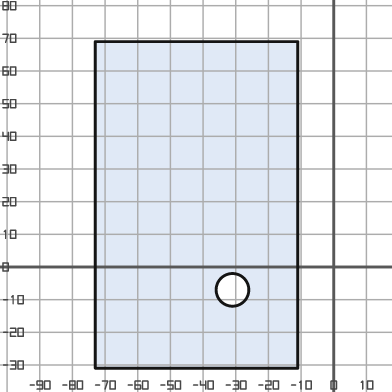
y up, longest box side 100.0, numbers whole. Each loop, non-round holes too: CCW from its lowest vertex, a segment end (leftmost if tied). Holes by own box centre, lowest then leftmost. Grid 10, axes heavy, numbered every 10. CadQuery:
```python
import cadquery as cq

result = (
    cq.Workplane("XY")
    .moveTo(-73.0, -31.0)
    .lineTo(-11.0, -31.0)
    .lineTo(-11.0, 69.0)
    .lineTo(-73.0, 69.0)
    .close()
    .moveTo(-31.0, -7.0)
    .circle(5.0)
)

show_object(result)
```